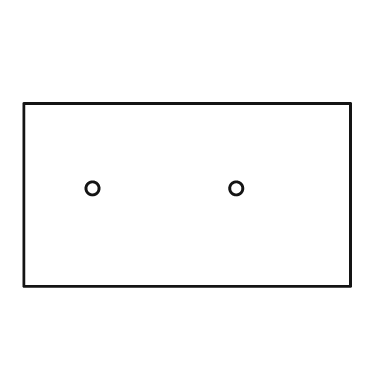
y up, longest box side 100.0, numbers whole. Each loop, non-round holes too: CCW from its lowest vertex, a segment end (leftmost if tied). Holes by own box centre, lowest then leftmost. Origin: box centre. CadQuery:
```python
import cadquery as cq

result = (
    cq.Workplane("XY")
    .moveTo(-50.0, -28.0)
    .lineTo(50.0, -28.0)
    .lineTo(50.0, 28.0)
    .lineTo(-50.0, 28.0)
    .close()
    .moveTo(-29.0, 2.0)
    .circle(2.0)
    .moveTo(15.0, 2.0)
    .circle(2.0)
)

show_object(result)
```